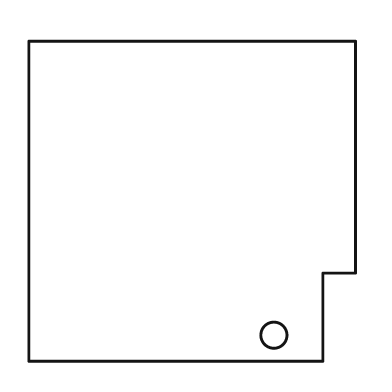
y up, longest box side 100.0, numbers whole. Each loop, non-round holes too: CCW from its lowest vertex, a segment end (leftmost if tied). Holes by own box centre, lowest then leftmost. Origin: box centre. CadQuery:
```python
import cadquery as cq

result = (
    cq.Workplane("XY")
    .moveTo(-50.0, -49.0)
    .lineTo(40.0, -49.0)
    .lineTo(40.0, -22.0)
    .lineTo(50.0, -22.0)
    .lineTo(50.0, 49.0)
    .lineTo(-50.0, 49.0)
    .close()
    .moveTo(25.0, -41.0)
    .circle(4.0)
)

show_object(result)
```